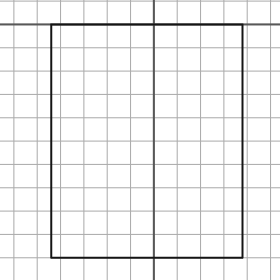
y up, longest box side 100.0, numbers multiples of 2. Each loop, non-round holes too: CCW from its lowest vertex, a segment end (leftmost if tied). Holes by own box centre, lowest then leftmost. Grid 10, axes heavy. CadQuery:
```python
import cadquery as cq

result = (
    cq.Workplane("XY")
    .moveTo(-44.0, -100.0)
    .lineTo(38.0, -100.0)
    .lineTo(38.0, 0.0)
    .lineTo(-44.0, 0.0)
    .close()
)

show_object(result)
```